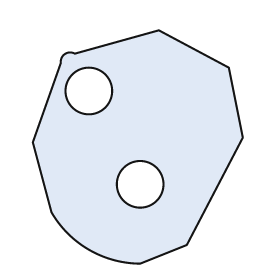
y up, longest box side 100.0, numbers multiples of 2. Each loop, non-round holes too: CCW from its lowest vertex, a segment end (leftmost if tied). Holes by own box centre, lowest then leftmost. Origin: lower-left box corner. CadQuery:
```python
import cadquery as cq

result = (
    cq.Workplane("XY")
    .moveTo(46.0, 0.0)
    .lineTo(66.0, 8.0)
    .lineTo(90.0, 54.0)
    .lineTo(84.0, 84.0)
    .lineTo(54.0, 100.0)
    .lineTo(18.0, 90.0)
    .threePointArc((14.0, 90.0), (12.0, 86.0))
    .lineTo(0.0, 52.0)
    .lineTo(8.0, 22.0)
    .threePointArc((24.0, 6.0), (46.0, 0.0))
    .close()
    .moveTo(46.0, 34.0)
    .circle(10.0)
    .moveTo(24.0, 74.0)
    .circle(10.0)
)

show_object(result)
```